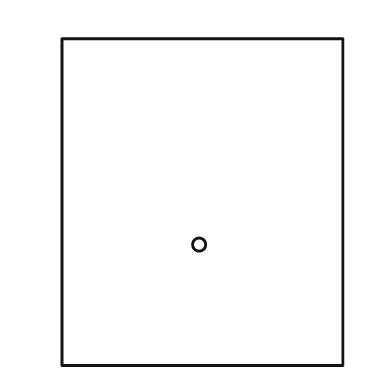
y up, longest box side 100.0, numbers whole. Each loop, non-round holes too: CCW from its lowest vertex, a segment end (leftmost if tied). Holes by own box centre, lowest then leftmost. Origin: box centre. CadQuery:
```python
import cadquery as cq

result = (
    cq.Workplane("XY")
    .moveTo(-43.0, -50.0)
    .lineTo(43.0, -50.0)
    .lineTo(43.0, 50.0)
    .lineTo(-43.0, 50.0)
    .close()
    .moveTo(-1.0, -13.0)
    .circle(2.0)
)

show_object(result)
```